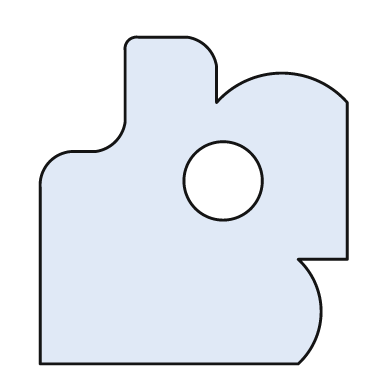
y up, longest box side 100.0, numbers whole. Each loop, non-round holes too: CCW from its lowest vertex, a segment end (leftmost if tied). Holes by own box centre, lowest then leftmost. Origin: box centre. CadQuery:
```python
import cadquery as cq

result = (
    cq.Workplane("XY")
    .moveTo(-47.0, -50.0)
    .lineTo(32.0, -50.0)
    .threePointArc((39.0, -34.0), (32.0, -18.0))
    .lineTo(47.0, -18.0)
    .lineTo(47.0, 30.0)
    .threePointArc((27.0, 39.0), (7.0, 30.0))
    .lineTo(7.0, 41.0)
    .threePointArc((4.0, 47.0), (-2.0, 50.0))
    .lineTo(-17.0, 50.0)
    .threePointArc((-20.0, 49.0), (-21.0, 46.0))
    .lineTo(-21.0, 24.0)
    .threePointArc((-24.0, 18.0), (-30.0, 15.0))
    .lineTo(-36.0, 15.0)
    .threePointArc((-44.0, 12.0), (-47.0, 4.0))
    .close()
    .moveTo(9.0, 6.0)
    .circle(12.0)
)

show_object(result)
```